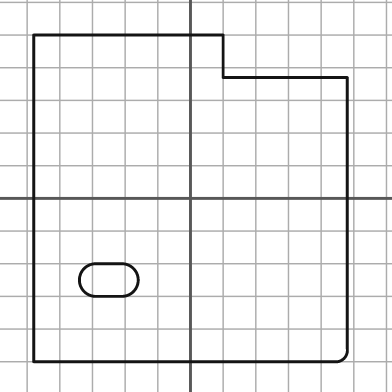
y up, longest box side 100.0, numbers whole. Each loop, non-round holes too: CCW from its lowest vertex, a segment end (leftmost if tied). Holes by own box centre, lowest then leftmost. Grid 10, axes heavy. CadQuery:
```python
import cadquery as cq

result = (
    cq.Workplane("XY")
    .moveTo(-48.0, -50.0)
    .lineTo(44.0, -50.0)
    .threePointArc((47.0, -49.0), (48.0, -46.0))
    .lineTo(48.0, 37.0)
    .lineTo(10.0, 37.0)
    .lineTo(10.0, 50.0)
    .lineTo(-48.0, 50.0)
    .close()
    .moveTo(-29.0, -30.0)
    .lineTo(-21.0, -30.0)
    .threePointArc((-16.0, -25.0), (-21.0, -20.0))
    .lineTo(-29.0, -20.0)
    .threePointArc((-34.0, -25.0), (-29.0, -30.0))
    .close()
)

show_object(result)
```